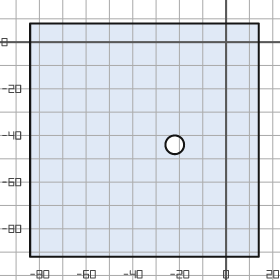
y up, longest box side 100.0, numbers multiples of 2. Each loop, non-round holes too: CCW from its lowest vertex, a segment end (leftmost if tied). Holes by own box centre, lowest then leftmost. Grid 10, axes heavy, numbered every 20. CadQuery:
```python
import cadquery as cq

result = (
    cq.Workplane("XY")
    .moveTo(-84.0, -92.0)
    .lineTo(14.0, -92.0)
    .lineTo(14.0, 8.0)
    .lineTo(-84.0, 8.0)
    .close()
    .moveTo(-22.0, -44.0)
    .circle(4.0)
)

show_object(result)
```